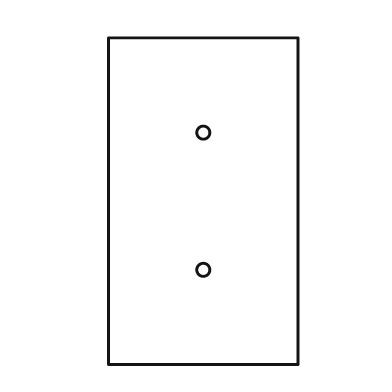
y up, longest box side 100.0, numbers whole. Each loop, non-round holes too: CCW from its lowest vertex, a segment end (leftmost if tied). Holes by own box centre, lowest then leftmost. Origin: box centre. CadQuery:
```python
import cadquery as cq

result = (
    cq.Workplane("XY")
    .moveTo(-29.0, -50.0)
    .lineTo(29.0, -50.0)
    .lineTo(29.0, 50.0)
    .lineTo(-29.0, 50.0)
    .close()
    .moveTo(0.0, -21.0)
    .circle(2.0)
    .moveTo(0.0, 21.0)
    .circle(2.0)
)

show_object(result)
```